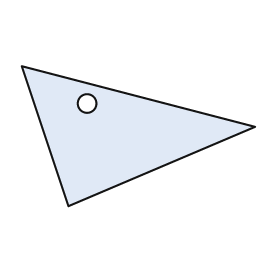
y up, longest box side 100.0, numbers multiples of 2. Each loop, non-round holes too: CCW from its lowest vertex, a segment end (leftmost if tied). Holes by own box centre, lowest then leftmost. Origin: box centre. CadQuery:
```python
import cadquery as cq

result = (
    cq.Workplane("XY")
    .moveTo(-30.0, -30.0)
    .lineTo(50.0, 4.0)
    .lineTo(-50.0, 30.0)
    .close()
    .moveTo(-22.0, 14.0)
    .circle(4.0)
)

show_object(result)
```